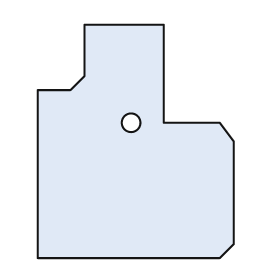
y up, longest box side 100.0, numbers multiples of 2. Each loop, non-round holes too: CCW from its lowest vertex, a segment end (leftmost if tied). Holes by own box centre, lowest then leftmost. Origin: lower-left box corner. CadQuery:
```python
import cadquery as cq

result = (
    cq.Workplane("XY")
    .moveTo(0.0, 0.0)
    .lineTo(78.0, 0.0)
    .lineTo(84.0, 6.0)
    .lineTo(84.0, 50.0)
    .lineTo(78.0, 58.0)
    .lineTo(54.0, 58.0)
    .lineTo(54.0, 100.0)
    .lineTo(20.0, 100.0)
    .lineTo(20.0, 78.0)
    .lineTo(14.0, 72.0)
    .lineTo(0.0, 72.0)
    .close()
    .moveTo(40.0, 58.0)
    .circle(4.0)
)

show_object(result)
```